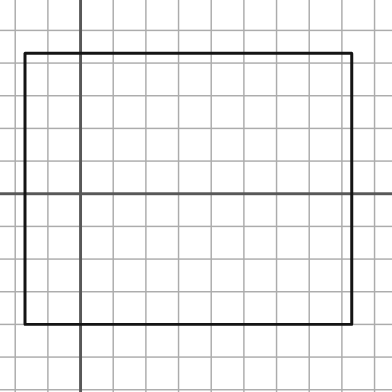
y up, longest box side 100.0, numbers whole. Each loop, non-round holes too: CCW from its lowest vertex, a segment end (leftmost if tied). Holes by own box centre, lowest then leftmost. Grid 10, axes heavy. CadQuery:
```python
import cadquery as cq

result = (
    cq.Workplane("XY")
    .moveTo(-17.0, -40.0)
    .lineTo(83.0, -40.0)
    .lineTo(83.0, 43.0)
    .lineTo(-17.0, 43.0)
    .close()
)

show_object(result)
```